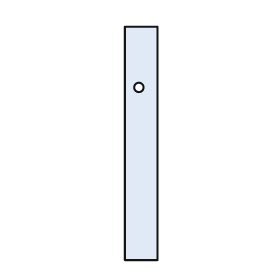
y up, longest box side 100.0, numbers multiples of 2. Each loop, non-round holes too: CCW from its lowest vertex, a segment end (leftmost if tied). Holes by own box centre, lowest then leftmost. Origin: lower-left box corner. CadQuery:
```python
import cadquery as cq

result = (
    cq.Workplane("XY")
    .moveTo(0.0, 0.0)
    .lineTo(14.0, 0.0)
    .lineTo(14.0, 100.0)
    .lineTo(0.0, 100.0)
    .close()
    .moveTo(6.0, 74.0)
    .circle(2.0)
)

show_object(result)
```